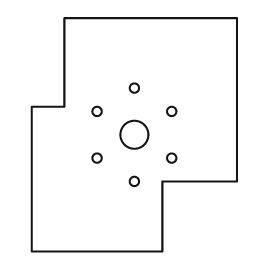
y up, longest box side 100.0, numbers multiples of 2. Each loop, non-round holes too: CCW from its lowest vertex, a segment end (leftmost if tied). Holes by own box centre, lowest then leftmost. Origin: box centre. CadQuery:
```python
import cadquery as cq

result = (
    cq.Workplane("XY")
    .moveTo(-44.0, -50.0)
    .lineTo(12.0, -50.0)
    .lineTo(12.0, -20.0)
    .lineTo(44.0, -20.0)
    .lineTo(44.0, 50.0)
    .lineTo(-30.0, 50.0)
    .lineTo(-30.0, 12.0)
    .lineTo(-44.0, 12.0)
    .close()
    .moveTo(0.0, -20.0)
    .circle(2.0)
    .moveTo(-16.0, -10.0)
    .circle(2.0)
    .moveTo(16.0, -10.0)
    .circle(2.0)
    .moveTo(0.0, 0.0)
    .circle(6.0)
    .moveTo(-16.0, 10.0)
    .circle(2.0)
    .moveTo(16.0, 10.0)
    .circle(2.0)
    .moveTo(0.0, 20.0)
    .circle(2.0)
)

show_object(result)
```